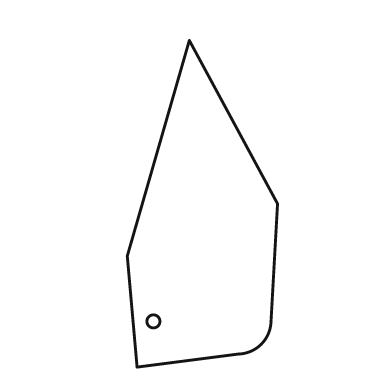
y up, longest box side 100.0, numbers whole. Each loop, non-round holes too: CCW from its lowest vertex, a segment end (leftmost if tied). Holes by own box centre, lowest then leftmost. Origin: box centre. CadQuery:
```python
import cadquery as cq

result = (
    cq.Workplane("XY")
    .moveTo(-20.0, -50.0)
    .lineTo(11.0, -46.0)
    .threePointArc((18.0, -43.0), (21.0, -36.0))
    .lineTo(23.0, 0.0)
    .lineTo(-4.0, 50.0)
    .lineTo(-23.0, -16.0)
    .close()
    .moveTo(-15.0, -36.0)
    .circle(2.0)
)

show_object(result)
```